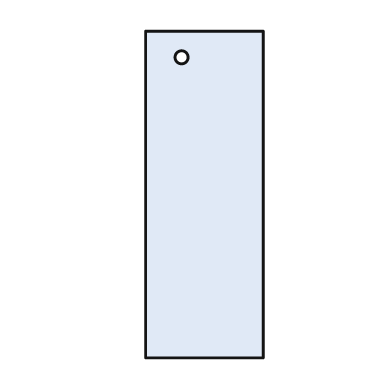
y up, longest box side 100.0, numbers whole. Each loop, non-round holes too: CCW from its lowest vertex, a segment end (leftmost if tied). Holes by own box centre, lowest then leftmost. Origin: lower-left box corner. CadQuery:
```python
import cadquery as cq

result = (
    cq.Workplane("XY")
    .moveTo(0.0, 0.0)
    .lineTo(36.0, 0.0)
    .lineTo(36.0, 100.0)
    .lineTo(0.0, 100.0)
    .close()
    .moveTo(11.0, 92.0)
    .circle(2.0)
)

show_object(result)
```